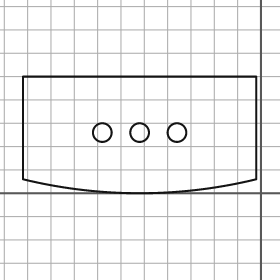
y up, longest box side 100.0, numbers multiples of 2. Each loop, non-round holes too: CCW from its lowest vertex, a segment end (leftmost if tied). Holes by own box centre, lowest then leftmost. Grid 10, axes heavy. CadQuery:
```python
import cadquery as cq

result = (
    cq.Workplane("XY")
    .moveTo(-102.0, 6.0)
    .threePointArc((-52.0, 0.0), (-2.0, 6.0))
    .lineTo(-2.0, 50.0)
    .lineTo(-102.0, 50.0)
    .close()
    .moveTo(-68.0, 26.0)
    .circle(4.0)
    .moveTo(-52.0, 26.0)
    .circle(4.0)
    .moveTo(-36.0, 26.0)
    .circle(4.0)
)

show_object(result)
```